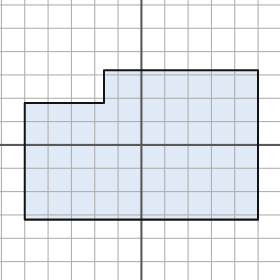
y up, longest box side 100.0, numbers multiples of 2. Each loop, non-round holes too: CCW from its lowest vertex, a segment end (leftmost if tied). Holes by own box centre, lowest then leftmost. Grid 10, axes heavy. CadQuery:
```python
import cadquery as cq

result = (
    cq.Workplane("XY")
    .moveTo(-50.0, -32.0)
    .lineTo(50.0, -32.0)
    .lineTo(50.0, 32.0)
    .lineTo(-16.0, 32.0)
    .lineTo(-16.0, 18.0)
    .lineTo(-50.0, 18.0)
    .close()
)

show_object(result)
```